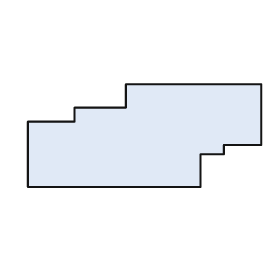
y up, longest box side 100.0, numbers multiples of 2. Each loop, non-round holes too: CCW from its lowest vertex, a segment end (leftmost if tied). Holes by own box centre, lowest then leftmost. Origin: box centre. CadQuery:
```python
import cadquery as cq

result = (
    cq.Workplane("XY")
    .moveTo(-50.0, -22.0)
    .lineTo(24.0, -22.0)
    .lineTo(24.0, -8.0)
    .lineTo(34.0, -8.0)
    .lineTo(34.0, -4.0)
    .lineTo(50.0, -4.0)
    .lineTo(50.0, 22.0)
    .lineTo(-8.0, 22.0)
    .lineTo(-8.0, 12.0)
    .lineTo(-30.0, 12.0)
    .lineTo(-30.0, 6.0)
    .lineTo(-50.0, 6.0)
    .close()
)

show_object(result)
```